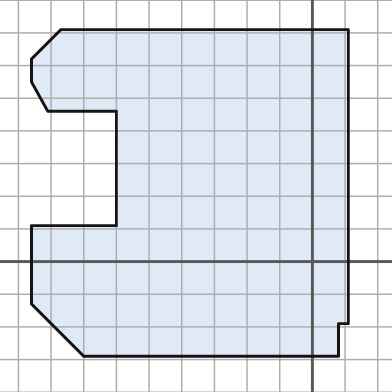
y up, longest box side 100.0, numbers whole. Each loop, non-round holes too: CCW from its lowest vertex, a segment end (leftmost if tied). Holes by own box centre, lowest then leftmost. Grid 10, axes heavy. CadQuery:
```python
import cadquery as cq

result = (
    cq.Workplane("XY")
    .moveTo(-70.0, -29.0)
    .lineTo(8.0, -29.0)
    .lineTo(8.0, -19.0)
    .lineTo(11.0, -19.0)
    .lineTo(11.0, 71.0)
    .lineTo(-77.0, 71.0)
    .lineTo(-86.0, 62.0)
    .lineTo(-86.0, 55.0)
    .lineTo(-81.0, 46.0)
    .lineTo(-60.0, 46.0)
    .lineTo(-60.0, 11.0)
    .lineTo(-86.0, 11.0)
    .lineTo(-86.0, -13.0)
    .close()
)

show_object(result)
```